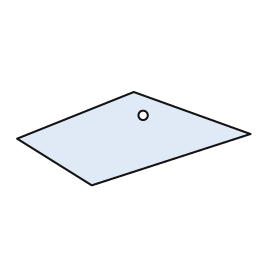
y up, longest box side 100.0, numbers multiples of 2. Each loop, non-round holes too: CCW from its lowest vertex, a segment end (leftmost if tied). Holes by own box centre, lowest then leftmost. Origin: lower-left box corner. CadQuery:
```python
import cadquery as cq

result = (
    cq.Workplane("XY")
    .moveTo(32.0, 0.0)
    .lineTo(100.0, 22.0)
    .lineTo(50.0, 40.0)
    .lineTo(0.0, 20.0)
    .close()
    .moveTo(54.0, 30.0)
    .circle(2.0)
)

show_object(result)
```